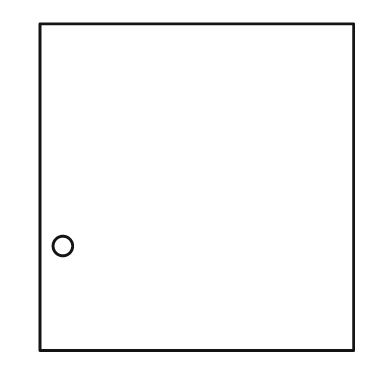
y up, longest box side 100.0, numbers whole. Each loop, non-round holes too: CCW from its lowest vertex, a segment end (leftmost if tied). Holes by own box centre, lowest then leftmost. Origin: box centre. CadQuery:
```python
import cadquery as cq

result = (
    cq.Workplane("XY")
    .moveTo(-48.0, -50.0)
    .lineTo(48.0, -50.0)
    .lineTo(48.0, 50.0)
    .lineTo(-48.0, 50.0)
    .close()
    .moveTo(-41.0, -18.0)
    .circle(3.0)
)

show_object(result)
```